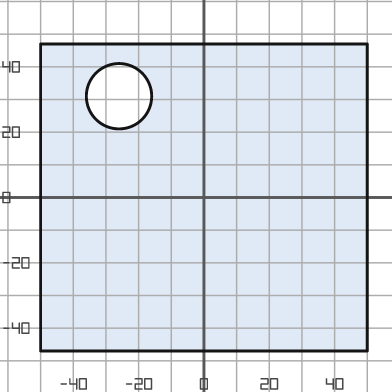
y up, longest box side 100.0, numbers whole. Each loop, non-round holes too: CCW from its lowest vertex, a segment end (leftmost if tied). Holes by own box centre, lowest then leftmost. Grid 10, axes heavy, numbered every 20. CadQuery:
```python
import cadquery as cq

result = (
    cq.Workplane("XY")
    .moveTo(-50.0, -47.0)
    .lineTo(50.0, -47.0)
    .lineTo(50.0, 47.0)
    .lineTo(-50.0, 47.0)
    .close()
    .moveTo(-26.0, 31.0)
    .circle(10.0)
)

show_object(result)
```